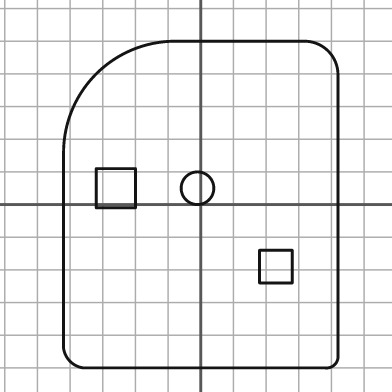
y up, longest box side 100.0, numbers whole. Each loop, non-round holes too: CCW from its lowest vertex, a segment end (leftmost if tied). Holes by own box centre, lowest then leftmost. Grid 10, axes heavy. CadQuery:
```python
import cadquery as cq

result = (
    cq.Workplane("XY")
    .moveTo(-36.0, -50.0)
    .lineTo(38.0, -50.0)
    .threePointArc((41.0, -49.0), (42.0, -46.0))
    .lineTo(42.0, 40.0)
    .threePointArc((39.0, 47.0), (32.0, 50.0))
    .lineTo(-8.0, 50.0)
    .threePointArc((-32.0, 40.0), (-42.0, 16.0))
    .lineTo(-42.0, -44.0)
    .threePointArc((-40.0, -48.0), (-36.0, -50.0))
    .close()
    .moveTo(18.0, -24.0)
    .lineTo(28.0, -24.0)
    .lineTo(28.0, -14.0)
    .lineTo(18.0, -14.0)
    .close()
    .moveTo(-32.0, -1.0)
    .lineTo(-20.0, -1.0)
    .lineTo(-20.0, 11.0)
    .lineTo(-32.0, 11.0)
    .close()
    .moveTo(-1.0, 5.0)
    .circle(5.0)
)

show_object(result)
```